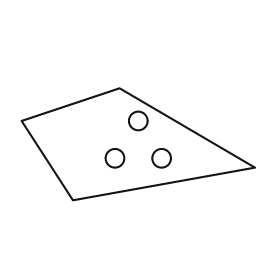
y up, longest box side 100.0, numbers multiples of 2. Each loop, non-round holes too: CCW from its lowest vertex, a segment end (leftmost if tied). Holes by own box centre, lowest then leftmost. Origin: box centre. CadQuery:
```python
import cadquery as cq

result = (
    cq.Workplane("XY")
    .moveTo(-28.0, -24.0)
    .lineTo(50.0, -10.0)
    .lineTo(-8.0, 24.0)
    .lineTo(-50.0, 10.0)
    .close()
    .moveTo(-10.0, -6.0)
    .circle(4.0)
    .moveTo(10.0, -6.0)
    .circle(4.0)
    .moveTo(0.0, 10.0)
    .circle(4.0)
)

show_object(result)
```